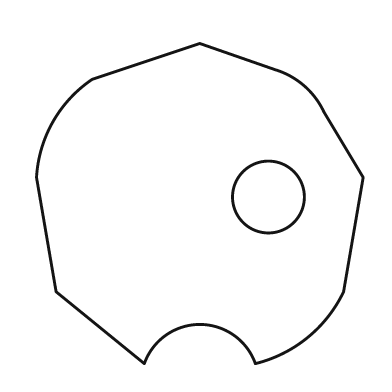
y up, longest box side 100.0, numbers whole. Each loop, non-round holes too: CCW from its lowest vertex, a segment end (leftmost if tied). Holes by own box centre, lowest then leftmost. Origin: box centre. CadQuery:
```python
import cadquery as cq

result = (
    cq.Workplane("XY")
    .moveTo(-17.0, -49.0)
    .threePointArc((0.0, -37.0), (17.0, -49.0))
    .threePointArc((33.0, -41.0), (44.0, -27.0))
    .lineTo(50.0, 8.0)
    .lineTo(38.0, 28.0)
    .threePointArc((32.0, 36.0), (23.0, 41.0))
    .lineTo(0.0, 49.0)
    .lineTo(-33.0, 38.0)
    .threePointArc((-45.0, 25.0), (-50.0, 8.0))
    .lineTo(-44.0, -27.0)
    .close()
    .moveTo(21.0, 2.0)
    .circle(11.0)
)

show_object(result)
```